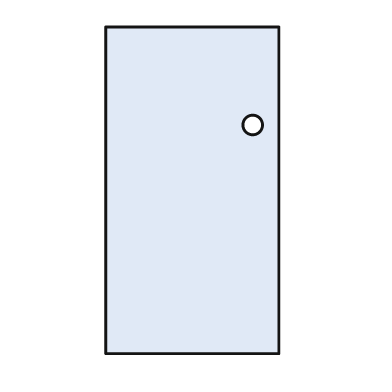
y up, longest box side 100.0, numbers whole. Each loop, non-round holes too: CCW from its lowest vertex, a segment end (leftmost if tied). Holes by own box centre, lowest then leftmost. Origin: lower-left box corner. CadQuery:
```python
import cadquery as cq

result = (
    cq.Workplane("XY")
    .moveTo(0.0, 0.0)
    .lineTo(53.0, 0.0)
    .lineTo(53.0, 100.0)
    .lineTo(0.0, 100.0)
    .close()
    .moveTo(45.0, 70.0)
    .circle(3.0)
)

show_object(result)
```